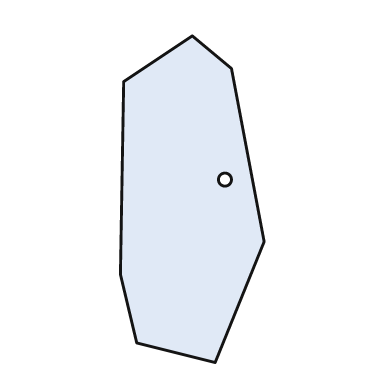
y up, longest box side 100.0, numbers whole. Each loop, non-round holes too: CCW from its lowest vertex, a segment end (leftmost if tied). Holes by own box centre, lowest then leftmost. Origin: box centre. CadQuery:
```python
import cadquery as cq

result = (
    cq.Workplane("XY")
    .moveTo(7.0, -50.0)
    .lineTo(22.0, -13.0)
    .lineTo(12.0, 40.0)
    .lineTo(0.0, 50.0)
    .lineTo(-21.0, 36.0)
    .lineTo(-22.0, -23.0)
    .lineTo(-17.0, -44.0)
    .close()
    .moveTo(10.0, 6.0)
    .circle(2.0)
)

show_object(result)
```